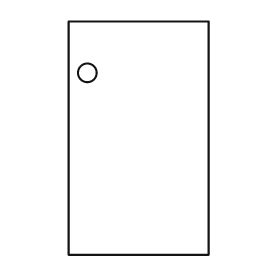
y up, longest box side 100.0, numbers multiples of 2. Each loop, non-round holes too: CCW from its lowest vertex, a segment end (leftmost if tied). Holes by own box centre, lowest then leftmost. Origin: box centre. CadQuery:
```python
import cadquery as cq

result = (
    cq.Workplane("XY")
    .moveTo(-30.0, -50.0)
    .lineTo(30.0, -50.0)
    .lineTo(30.0, 50.0)
    .lineTo(-30.0, 50.0)
    .close()
    .moveTo(-22.0, 28.0)
    .circle(4.0)
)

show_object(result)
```